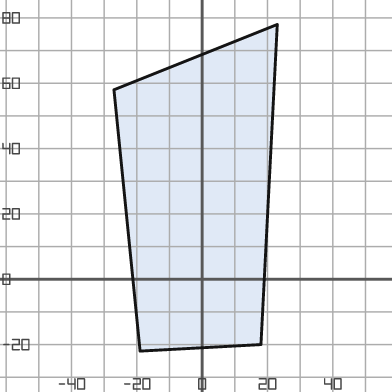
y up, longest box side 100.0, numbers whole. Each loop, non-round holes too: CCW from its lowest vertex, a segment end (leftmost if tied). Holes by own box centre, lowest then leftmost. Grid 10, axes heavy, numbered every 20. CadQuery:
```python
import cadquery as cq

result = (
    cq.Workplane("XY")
    .moveTo(-19.0, -22.0)
    .lineTo(18.0, -20.0)
    .lineTo(23.0, 78.0)
    .lineTo(-27.0, 58.0)
    .close()
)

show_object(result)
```